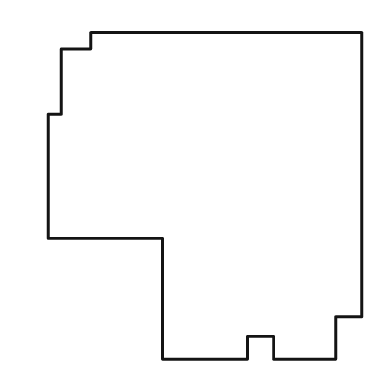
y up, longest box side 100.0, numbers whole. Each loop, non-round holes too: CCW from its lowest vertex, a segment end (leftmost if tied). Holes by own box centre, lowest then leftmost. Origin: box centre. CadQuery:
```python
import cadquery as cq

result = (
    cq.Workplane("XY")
    .moveTo(-13.0, -50.0)
    .lineTo(13.0, -50.0)
    .lineTo(13.0, -43.0)
    .lineTo(21.0, -43.0)
    .lineTo(21.0, -50.0)
    .lineTo(40.0, -50.0)
    .lineTo(40.0, -37.0)
    .lineTo(48.0, -37.0)
    .lineTo(48.0, 50.0)
    .lineTo(-35.0, 50.0)
    .lineTo(-35.0, 45.0)
    .lineTo(-44.0, 45.0)
    .lineTo(-44.0, 25.0)
    .lineTo(-48.0, 25.0)
    .lineTo(-48.0, -13.0)
    .lineTo(-13.0, -13.0)
    .close()
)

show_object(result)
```